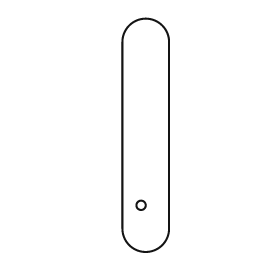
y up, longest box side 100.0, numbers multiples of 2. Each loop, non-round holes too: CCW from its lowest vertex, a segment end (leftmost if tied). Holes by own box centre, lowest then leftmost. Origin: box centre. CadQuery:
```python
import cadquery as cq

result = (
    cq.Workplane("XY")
    .moveTo(-10.0, -40.0)
    .threePointArc((0.0, -50.0), (10.0, -40.0))
    .lineTo(10.0, 40.0)
    .threePointArc((0.0, 50.0), (-10.0, 40.0))
    .close()
    .moveTo(-2.0, -30.0)
    .circle(2.0)
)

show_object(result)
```